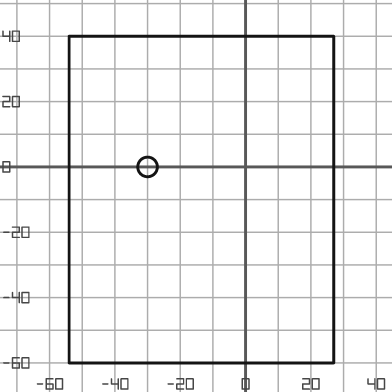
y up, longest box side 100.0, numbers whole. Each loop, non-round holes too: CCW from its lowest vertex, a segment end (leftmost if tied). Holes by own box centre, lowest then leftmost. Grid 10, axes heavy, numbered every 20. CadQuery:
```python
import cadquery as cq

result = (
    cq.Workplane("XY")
    .moveTo(-54.0, -60.0)
    .lineTo(27.0, -60.0)
    .lineTo(27.0, 40.0)
    .lineTo(-54.0, 40.0)
    .close()
    .moveTo(-30.0, 0.0)
    .circle(3.0)
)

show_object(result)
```